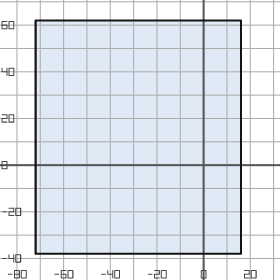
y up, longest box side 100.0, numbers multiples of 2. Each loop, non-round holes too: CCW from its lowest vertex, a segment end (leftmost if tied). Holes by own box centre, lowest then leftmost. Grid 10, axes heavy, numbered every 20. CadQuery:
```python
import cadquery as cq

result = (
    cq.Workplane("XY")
    .moveTo(-72.0, -38.0)
    .lineTo(16.0, -38.0)
    .lineTo(16.0, 62.0)
    .lineTo(-72.0, 62.0)
    .close()
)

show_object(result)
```